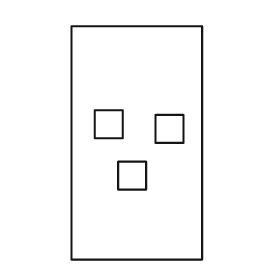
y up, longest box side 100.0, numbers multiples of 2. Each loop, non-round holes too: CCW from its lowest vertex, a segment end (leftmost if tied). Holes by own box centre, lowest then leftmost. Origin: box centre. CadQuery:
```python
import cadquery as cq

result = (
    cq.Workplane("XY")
    .moveTo(-28.0, -50.0)
    .lineTo(28.0, -50.0)
    .lineTo(28.0, 50.0)
    .lineTo(-28.0, 50.0)
    .close()
    .moveTo(-8.0, -20.0)
    .lineTo(4.0, -20.0)
    .lineTo(4.0, -8.0)
    .lineTo(-8.0, -8.0)
    .close()
    .moveTo(8.0, 0.0)
    .lineTo(20.0, 0.0)
    .lineTo(20.0, 12.0)
    .lineTo(8.0, 12.0)
    .close()
    .moveTo(-18.0, 2.0)
    .lineTo(-6.0, 2.0)
    .lineTo(-6.0, 14.0)
    .lineTo(-18.0, 14.0)
    .close()
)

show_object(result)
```